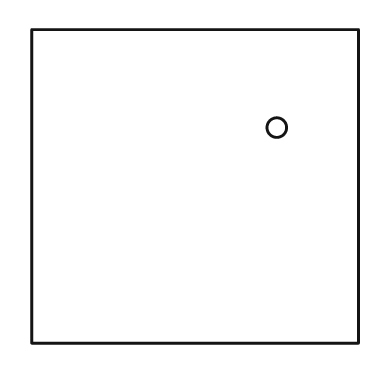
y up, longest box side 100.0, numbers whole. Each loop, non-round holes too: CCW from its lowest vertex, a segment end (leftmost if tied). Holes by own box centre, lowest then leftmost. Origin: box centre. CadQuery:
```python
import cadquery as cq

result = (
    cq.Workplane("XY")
    .moveTo(-50.0, -48.0)
    .lineTo(50.0, -48.0)
    .lineTo(50.0, 48.0)
    .lineTo(-50.0, 48.0)
    .close()
    .moveTo(25.0, 18.0)
    .circle(3.0)
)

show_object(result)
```